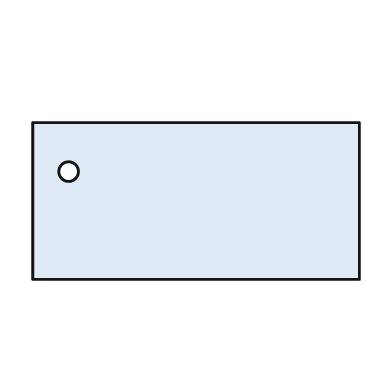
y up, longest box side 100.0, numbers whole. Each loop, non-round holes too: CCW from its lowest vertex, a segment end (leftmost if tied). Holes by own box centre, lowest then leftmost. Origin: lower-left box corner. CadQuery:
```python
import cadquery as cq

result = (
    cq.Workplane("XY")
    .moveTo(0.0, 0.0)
    .lineTo(100.0, 0.0)
    .lineTo(100.0, 48.0)
    .lineTo(0.0, 48.0)
    .close()
    .moveTo(11.0, 33.0)
    .circle(3.0)
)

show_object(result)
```